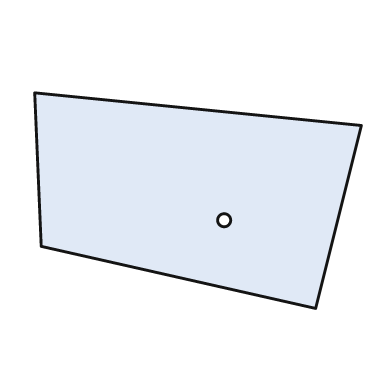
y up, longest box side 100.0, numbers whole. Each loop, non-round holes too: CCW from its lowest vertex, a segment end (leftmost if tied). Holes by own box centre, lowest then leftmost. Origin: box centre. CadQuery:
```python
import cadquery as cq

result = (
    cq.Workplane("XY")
    .moveTo(36.0, -33.0)
    .lineTo(50.0, 23.0)
    .lineTo(-50.0, 33.0)
    .lineTo(-48.0, -14.0)
    .close()
    .moveTo(8.0, -6.0)
    .circle(2.0)
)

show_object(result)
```